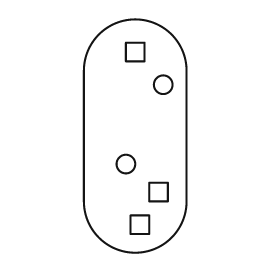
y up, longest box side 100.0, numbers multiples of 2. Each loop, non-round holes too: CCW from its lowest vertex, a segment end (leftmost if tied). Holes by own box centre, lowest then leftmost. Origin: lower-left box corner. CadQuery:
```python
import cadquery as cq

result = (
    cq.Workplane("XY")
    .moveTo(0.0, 22.0)
    .threePointArc((22.0, 0.0), (44.0, 22.0))
    .lineTo(44.0, 78.0)
    .threePointArc((22.0, 100.0), (0.0, 78.0))
    .close()
    .moveTo(20.0, 8.0)
    .lineTo(28.0, 8.0)
    .lineTo(28.0, 16.0)
    .lineTo(20.0, 16.0)
    .close()
    .moveTo(28.0, 22.0)
    .lineTo(36.0, 22.0)
    .lineTo(36.0, 30.0)
    .lineTo(28.0, 30.0)
    .close()
    .moveTo(18.0, 38.0)
    .circle(4.0)
    .moveTo(34.0, 72.0)
    .circle(4.0)
    .moveTo(18.0, 82.0)
    .lineTo(26.0, 82.0)
    .lineTo(26.0, 90.0)
    .lineTo(18.0, 90.0)
    .close()
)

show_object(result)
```